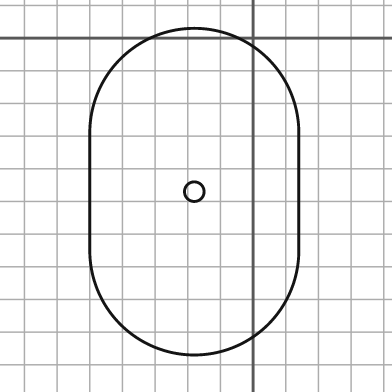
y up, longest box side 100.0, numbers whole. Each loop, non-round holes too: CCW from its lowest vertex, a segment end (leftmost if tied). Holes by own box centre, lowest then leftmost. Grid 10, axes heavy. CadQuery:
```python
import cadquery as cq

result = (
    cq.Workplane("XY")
    .moveTo(-50.0, -65.0)
    .threePointArc((-18.0, -97.0), (14.0, -65.0))
    .lineTo(14.0, -29.0)
    .threePointArc((-18.0, 3.0), (-50.0, -29.0))
    .close()
    .moveTo(-18.0, -47.0)
    .circle(3.0)
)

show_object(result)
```